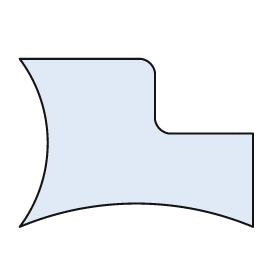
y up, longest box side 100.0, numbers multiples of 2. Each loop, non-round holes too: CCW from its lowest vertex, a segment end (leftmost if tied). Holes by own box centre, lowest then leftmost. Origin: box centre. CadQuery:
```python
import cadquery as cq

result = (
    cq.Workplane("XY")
    .moveTo(-50.0, -36.0)
    .threePointArc((0.0, -26.0), (50.0, -36.0))
    .lineTo(50.0, 4.0)
    .lineTo(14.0, 4.0)
    .threePointArc((10.0, 6.0), (8.0, 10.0))
    .lineTo(8.0, 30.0)
    .threePointArc((6.0, 34.0), (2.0, 36.0))
    .lineTo(-50.0, 36.0)
    .threePointArc((-38.0, 0.0), (-50.0, -36.0))
    .close()
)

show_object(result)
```